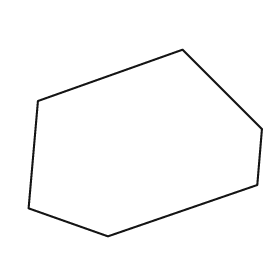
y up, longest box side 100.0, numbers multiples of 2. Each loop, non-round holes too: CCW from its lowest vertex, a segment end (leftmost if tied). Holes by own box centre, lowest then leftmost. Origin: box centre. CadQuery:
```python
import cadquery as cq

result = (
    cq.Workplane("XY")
    .moveTo(-16.0, -40.0)
    .lineTo(48.0, -18.0)
    .lineTo(50.0, 6.0)
    .lineTo(16.0, 40.0)
    .lineTo(-46.0, 18.0)
    .lineTo(-50.0, -28.0)
    .close()
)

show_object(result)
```